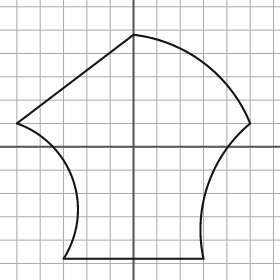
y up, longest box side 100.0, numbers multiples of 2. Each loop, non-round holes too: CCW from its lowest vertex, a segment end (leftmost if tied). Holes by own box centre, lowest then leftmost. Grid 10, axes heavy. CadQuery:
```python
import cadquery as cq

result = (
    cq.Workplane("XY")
    .moveTo(-30.0, -48.0)
    .lineTo(30.0, -48.0)
    .threePointArc((32.0, -16.0), (50.0, 10.0))
    .threePointArc((30.0, 36.0), (0.0, 48.0))
    .lineTo(-50.0, 10.0)
    .threePointArc((-26.0, -14.0), (-30.0, -48.0))
    .close()
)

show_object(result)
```